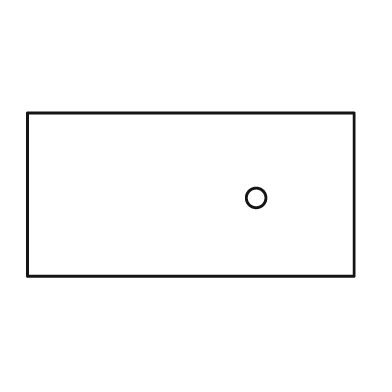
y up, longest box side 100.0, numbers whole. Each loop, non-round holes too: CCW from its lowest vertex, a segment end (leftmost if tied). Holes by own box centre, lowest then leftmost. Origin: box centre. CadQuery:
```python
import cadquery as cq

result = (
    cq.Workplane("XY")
    .moveTo(-50.0, -25.0)
    .lineTo(50.0, -25.0)
    .lineTo(50.0, 25.0)
    .lineTo(-50.0, 25.0)
    .close()
    .moveTo(20.0, -1.0)
    .circle(3.0)
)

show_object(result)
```